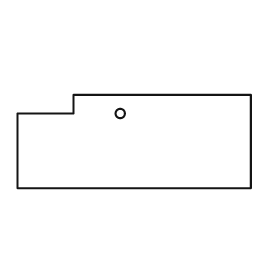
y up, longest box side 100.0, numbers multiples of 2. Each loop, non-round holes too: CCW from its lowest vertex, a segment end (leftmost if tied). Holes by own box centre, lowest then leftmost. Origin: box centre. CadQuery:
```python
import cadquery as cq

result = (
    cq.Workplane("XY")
    .moveTo(-50.0, -20.0)
    .lineTo(50.0, -20.0)
    .lineTo(50.0, 20.0)
    .lineTo(-26.0, 20.0)
    .lineTo(-26.0, 12.0)
    .lineTo(-50.0, 12.0)
    .close()
    .moveTo(-6.0, 12.0)
    .circle(2.0)
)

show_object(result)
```